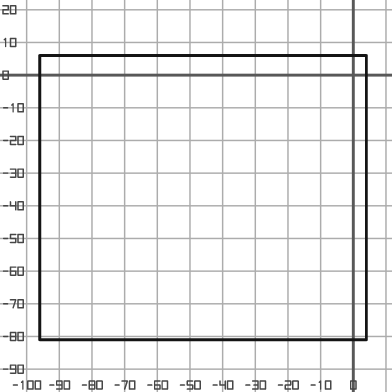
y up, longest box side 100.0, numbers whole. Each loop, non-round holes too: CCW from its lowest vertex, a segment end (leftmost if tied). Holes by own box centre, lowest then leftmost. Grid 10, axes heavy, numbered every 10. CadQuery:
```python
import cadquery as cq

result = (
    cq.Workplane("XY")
    .moveTo(-96.0, -81.0)
    .lineTo(4.0, -81.0)
    .lineTo(4.0, 6.0)
    .lineTo(-96.0, 6.0)
    .close()
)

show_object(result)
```